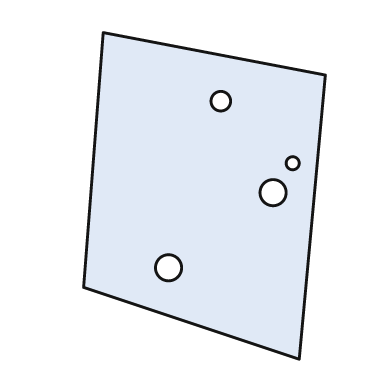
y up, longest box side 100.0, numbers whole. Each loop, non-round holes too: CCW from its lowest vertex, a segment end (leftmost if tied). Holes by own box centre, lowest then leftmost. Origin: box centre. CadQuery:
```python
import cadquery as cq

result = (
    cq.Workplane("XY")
    .moveTo(29.0, -50.0)
    .lineTo(37.0, 37.0)
    .lineTo(-31.0, 50.0)
    .lineTo(-37.0, -28.0)
    .close()
    .moveTo(-11.0, -22.0)
    .circle(4.0)
    .moveTo(21.0, 1.0)
    .circle(4.0)
    .moveTo(27.0, 10.0)
    .circle(2.0)
    .moveTo(5.0, 29.0)
    .circle(3.0)
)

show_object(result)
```